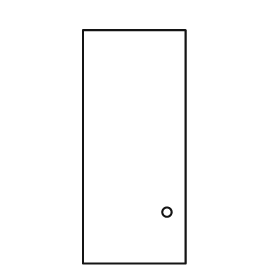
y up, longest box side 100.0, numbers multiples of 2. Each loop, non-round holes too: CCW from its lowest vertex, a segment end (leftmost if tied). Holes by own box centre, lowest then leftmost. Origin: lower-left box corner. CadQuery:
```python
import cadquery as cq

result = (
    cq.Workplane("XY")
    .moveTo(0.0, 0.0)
    .lineTo(44.0, 0.0)
    .lineTo(44.0, 100.0)
    .lineTo(0.0, 100.0)
    .close()
    .moveTo(36.0, 22.0)
    .circle(2.0)
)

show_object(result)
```